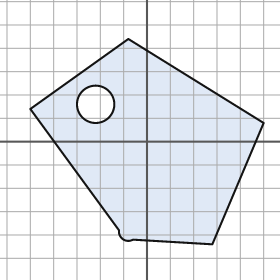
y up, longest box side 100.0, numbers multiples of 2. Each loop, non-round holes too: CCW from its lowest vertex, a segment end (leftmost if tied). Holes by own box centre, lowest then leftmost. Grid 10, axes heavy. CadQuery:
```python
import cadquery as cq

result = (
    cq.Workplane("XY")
    .moveTo(28.0, -44.0)
    .lineTo(50.0, 8.0)
    .lineTo(-8.0, 44.0)
    .lineTo(-50.0, 14.0)
    .lineTo(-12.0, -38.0)
    .threePointArc((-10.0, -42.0), (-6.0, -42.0))
    .close()
    .moveTo(-22.0, 16.0)
    .circle(8.0)
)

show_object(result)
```